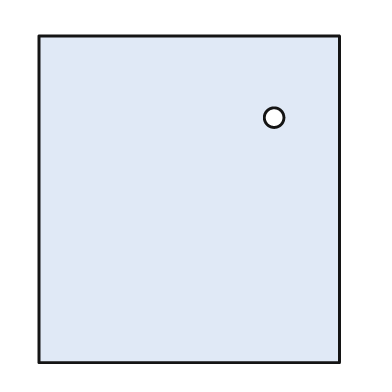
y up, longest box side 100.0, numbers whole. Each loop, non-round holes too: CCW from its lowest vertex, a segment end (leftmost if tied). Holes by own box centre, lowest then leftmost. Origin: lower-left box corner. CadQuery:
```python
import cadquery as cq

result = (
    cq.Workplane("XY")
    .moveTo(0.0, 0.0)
    .lineTo(92.0, 0.0)
    .lineTo(92.0, 100.0)
    .lineTo(0.0, 100.0)
    .close()
    .moveTo(72.0, 75.0)
    .circle(3.0)
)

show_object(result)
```